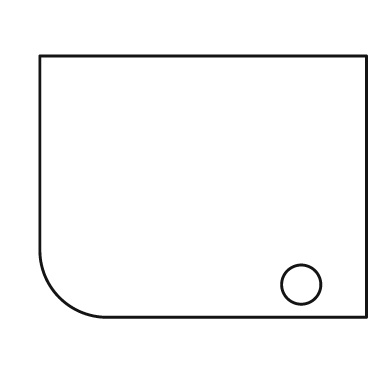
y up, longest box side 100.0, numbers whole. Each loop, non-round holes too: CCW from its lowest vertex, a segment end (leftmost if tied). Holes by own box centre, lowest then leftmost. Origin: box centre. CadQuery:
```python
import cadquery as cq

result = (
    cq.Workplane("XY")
    .moveTo(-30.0, -40.0)
    .lineTo(50.0, -40.0)
    .lineTo(50.0, 40.0)
    .lineTo(-50.0, 40.0)
    .lineTo(-50.0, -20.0)
    .threePointArc((-44.0, -34.0), (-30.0, -40.0))
    .close()
    .moveTo(30.0, -30.0)
    .circle(6.0)
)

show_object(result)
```